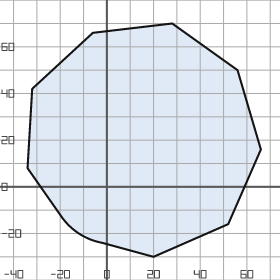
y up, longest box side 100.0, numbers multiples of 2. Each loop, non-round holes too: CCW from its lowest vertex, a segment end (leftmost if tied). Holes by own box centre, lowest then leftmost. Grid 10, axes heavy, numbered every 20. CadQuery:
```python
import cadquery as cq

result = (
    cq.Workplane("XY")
    .moveTo(20.0, -30.0)
    .lineTo(52.0, -16.0)
    .lineTo(66.0, 16.0)
    .lineTo(56.0, 50.0)
    .lineTo(28.0, 70.0)
    .lineTo(-6.0, 66.0)
    .lineTo(-32.0, 42.0)
    .lineTo(-34.0, 8.0)
    .lineTo(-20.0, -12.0)
    .threePointArc((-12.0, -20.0), (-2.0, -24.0))
    .close()
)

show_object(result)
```